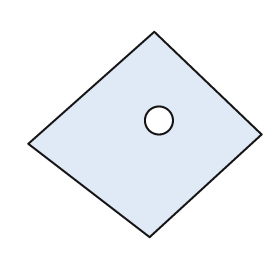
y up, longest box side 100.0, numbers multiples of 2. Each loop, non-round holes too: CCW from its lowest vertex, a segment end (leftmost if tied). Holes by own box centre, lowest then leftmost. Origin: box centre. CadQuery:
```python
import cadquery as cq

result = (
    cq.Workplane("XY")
    .moveTo(2.0, -44.0)
    .lineTo(50.0, 0.0)
    .lineTo(4.0, 44.0)
    .lineTo(-50.0, -4.0)
    .close()
    .moveTo(6.0, 6.0)
    .circle(6.0)
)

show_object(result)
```